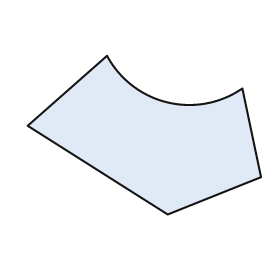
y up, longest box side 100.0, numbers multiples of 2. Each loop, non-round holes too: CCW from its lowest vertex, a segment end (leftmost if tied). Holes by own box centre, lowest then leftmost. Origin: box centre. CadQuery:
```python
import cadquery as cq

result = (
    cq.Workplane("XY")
    .moveTo(10.0, -34.0)
    .lineTo(50.0, -18.0)
    .lineTo(42.0, 20.0)
    .threePointArc((10.0, 14.0), (-16.0, 34.0))
    .lineTo(-50.0, 4.0)
    .close()
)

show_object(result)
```